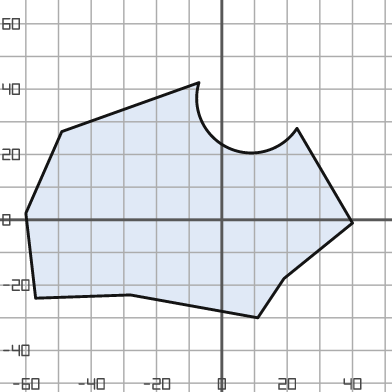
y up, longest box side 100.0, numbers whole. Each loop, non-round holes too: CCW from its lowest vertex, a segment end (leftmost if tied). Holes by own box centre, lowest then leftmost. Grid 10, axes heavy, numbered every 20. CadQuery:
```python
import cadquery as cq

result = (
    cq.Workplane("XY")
    .moveTo(11.0, -30.0)
    .lineTo(19.0, -18.0)
    .lineTo(40.0, -1.0)
    .lineTo(23.0, 28.0)
    .threePointArc((2.0, 22.0), (-7.0, 42.0))
    .lineTo(-49.0, 27.0)
    .lineTo(-60.0, 2.0)
    .lineTo(-57.0, -24.0)
    .lineTo(-28.0, -23.0)
    .close()
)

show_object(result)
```